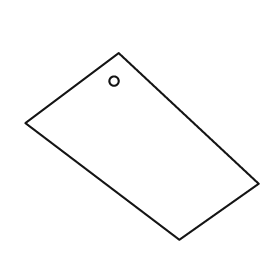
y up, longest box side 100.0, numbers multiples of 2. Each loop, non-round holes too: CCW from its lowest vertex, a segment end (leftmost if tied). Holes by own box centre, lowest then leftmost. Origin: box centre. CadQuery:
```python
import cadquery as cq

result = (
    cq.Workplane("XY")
    .moveTo(16.0, -40.0)
    .lineTo(50.0, -16.0)
    .lineTo(-10.0, 40.0)
    .lineTo(-50.0, 10.0)
    .close()
    .moveTo(-12.0, 28.0)
    .circle(2.0)
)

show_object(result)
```